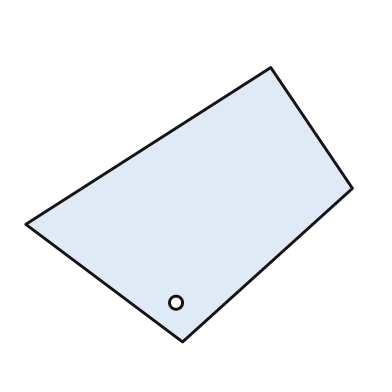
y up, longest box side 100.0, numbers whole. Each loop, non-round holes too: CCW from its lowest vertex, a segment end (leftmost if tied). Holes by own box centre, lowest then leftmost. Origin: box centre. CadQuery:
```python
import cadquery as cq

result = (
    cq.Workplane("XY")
    .moveTo(-2.0, -42.0)
    .lineTo(50.0, 5.0)
    .lineTo(25.0, 42.0)
    .lineTo(-50.0, -6.0)
    .close()
    .moveTo(-4.0, -30.0)
    .circle(2.0)
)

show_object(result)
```